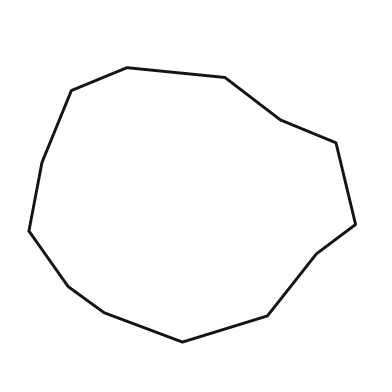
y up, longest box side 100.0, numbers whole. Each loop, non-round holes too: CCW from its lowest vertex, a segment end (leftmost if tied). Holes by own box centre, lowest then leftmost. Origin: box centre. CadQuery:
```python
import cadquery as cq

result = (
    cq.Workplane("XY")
    .moveTo(-3.0, -42.0)
    .lineTo(23.0, -34.0)
    .lineTo(38.0, -15.0)
    .lineTo(50.0, -6.0)
    .lineTo(44.0, 19.0)
    .lineTo(27.0, 26.0)
    .lineTo(10.0, 39.0)
    .lineTo(-20.0, 42.0)
    .lineTo(-37.0, 35.0)
    .lineTo(-46.0, 13.0)
    .lineTo(-50.0, -8.0)
    .lineTo(-38.0, -25.0)
    .lineTo(-27.0, -33.0)
    .close()
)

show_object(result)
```